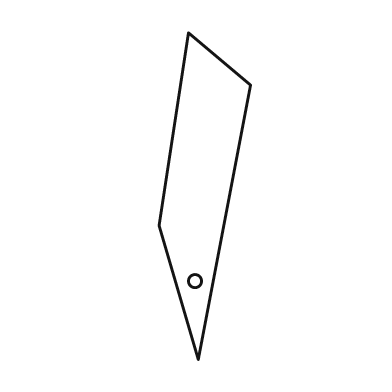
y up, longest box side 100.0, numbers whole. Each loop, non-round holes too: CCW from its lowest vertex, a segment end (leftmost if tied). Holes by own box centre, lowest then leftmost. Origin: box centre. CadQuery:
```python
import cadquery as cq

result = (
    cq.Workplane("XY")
    .moveTo(-2.0, -50.0)
    .lineTo(14.0, 34.0)
    .lineTo(-5.0, 50.0)
    .lineTo(-14.0, -9.0)
    .close()
    .moveTo(-3.0, -26.0)
    .circle(2.0)
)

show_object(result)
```